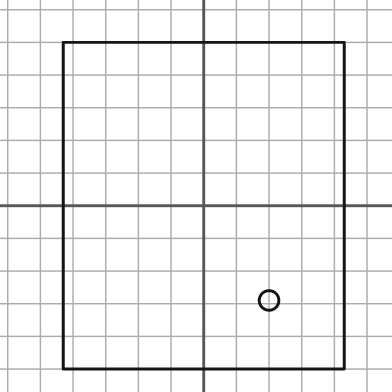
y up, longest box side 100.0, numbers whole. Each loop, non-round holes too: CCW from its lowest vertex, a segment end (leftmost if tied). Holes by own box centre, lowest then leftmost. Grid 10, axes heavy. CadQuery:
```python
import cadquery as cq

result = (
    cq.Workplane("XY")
    .moveTo(-43.0, -50.0)
    .lineTo(43.0, -50.0)
    .lineTo(43.0, 50.0)
    .lineTo(-43.0, 50.0)
    .close()
    .moveTo(20.0, -29.0)
    .circle(3.0)
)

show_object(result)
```